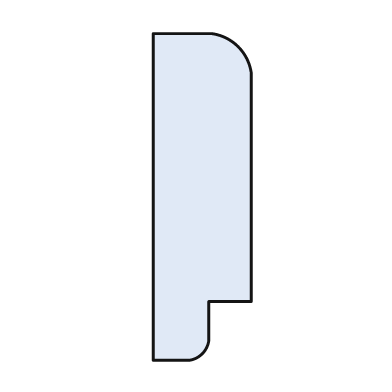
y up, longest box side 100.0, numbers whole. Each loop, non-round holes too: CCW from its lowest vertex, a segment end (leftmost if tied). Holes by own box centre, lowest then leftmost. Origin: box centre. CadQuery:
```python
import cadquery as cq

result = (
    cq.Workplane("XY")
    .moveTo(-15.0, -50.0)
    .lineTo(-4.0, -50.0)
    .threePointArc((0.0, -48.0), (2.0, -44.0))
    .lineTo(2.0, -32.0)
    .lineTo(15.0, -32.0)
    .lineTo(15.0, 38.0)
    .threePointArc((11.0, 46.0), (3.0, 50.0))
    .lineTo(-15.0, 50.0)
    .close()
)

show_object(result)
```